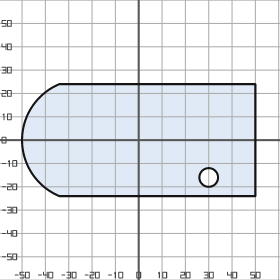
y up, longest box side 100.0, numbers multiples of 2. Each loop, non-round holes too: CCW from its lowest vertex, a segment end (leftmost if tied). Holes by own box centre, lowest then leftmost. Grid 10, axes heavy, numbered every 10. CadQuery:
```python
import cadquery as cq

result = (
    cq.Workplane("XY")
    .moveTo(-34.0, -24.0)
    .lineTo(50.0, -24.0)
    .lineTo(50.0, 24.0)
    .lineTo(-34.0, 24.0)
    .threePointArc((-50.0, 0.0), (-34.0, -24.0))
    .close()
    .moveTo(30.0, -16.0)
    .circle(4.0)
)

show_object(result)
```